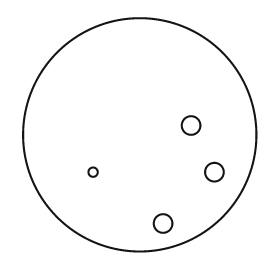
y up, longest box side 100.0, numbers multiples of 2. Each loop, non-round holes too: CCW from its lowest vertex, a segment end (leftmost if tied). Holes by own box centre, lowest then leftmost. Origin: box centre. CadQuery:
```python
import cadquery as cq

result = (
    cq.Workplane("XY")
    .moveTo(0.0, 0.0)
    .circle(50.0)
    .moveTo(10.0, -38.0)
    .circle(4.0)
    .moveTo(-20.0, -16.0)
    .circle(2.0)
    .moveTo(32.0, -16.0)
    .circle(4.0)
    .moveTo(22.0, 4.0)
    .circle(4.0)
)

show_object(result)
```